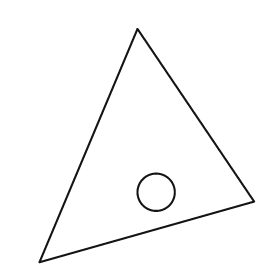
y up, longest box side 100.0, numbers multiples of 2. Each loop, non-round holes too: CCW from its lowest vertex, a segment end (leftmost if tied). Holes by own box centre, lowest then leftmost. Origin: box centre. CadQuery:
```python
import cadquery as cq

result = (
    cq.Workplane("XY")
    .moveTo(-46.0, -50.0)
    .lineTo(46.0, -24.0)
    .lineTo(-4.0, 50.0)
    .close()
    .moveTo(4.0, -20.0)
    .circle(8.0)
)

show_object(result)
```